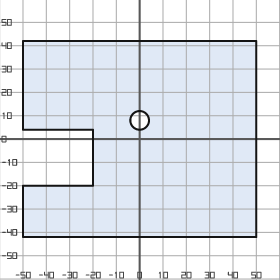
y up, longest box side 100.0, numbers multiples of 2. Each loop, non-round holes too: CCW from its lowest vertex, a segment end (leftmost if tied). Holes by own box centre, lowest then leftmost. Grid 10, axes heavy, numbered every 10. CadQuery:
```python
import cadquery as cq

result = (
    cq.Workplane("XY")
    .moveTo(-50.0, -42.0)
    .lineTo(50.0, -42.0)
    .lineTo(50.0, 42.0)
    .lineTo(-50.0, 42.0)
    .lineTo(-50.0, 4.0)
    .lineTo(-20.0, 4.0)
    .lineTo(-20.0, -20.0)
    .lineTo(-50.0, -20.0)
    .close()
    .moveTo(0.0, 8.0)
    .circle(4.0)
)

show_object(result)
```